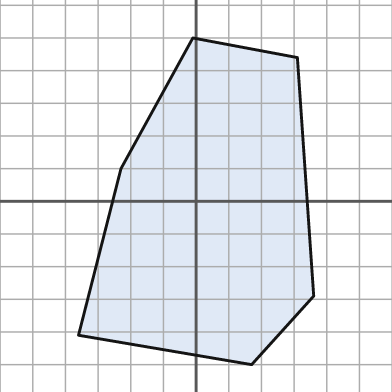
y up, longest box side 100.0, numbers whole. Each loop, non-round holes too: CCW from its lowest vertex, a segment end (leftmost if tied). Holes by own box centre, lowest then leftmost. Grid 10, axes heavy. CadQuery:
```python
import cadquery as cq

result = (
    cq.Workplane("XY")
    .moveTo(17.0, -50.0)
    .lineTo(36.0, -29.0)
    .lineTo(31.0, 44.0)
    .lineTo(-1.0, 50.0)
    .lineTo(-23.0, 10.0)
    .lineTo(-36.0, -41.0)
    .close()
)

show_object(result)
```